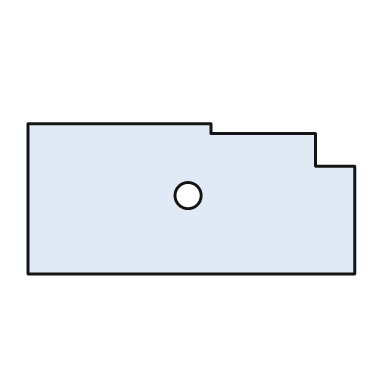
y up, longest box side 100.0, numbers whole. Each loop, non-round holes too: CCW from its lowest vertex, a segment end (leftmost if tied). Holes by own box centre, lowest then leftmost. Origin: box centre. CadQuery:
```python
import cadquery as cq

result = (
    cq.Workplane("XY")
    .moveTo(-50.0, -23.0)
    .lineTo(50.0, -23.0)
    .lineTo(50.0, 10.0)
    .lineTo(38.0, 10.0)
    .lineTo(38.0, 20.0)
    .lineTo(6.0, 20.0)
    .lineTo(6.0, 23.0)
    .lineTo(-50.0, 23.0)
    .close()
    .moveTo(-1.0, 1.0)
    .circle(4.0)
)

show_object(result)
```